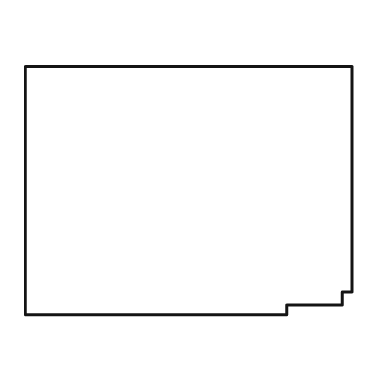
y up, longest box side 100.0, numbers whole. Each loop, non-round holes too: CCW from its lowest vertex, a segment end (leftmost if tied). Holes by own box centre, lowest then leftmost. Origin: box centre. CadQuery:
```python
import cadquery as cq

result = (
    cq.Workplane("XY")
    .moveTo(-50.0, -38.0)
    .lineTo(30.0, -38.0)
    .lineTo(30.0, -35.0)
    .lineTo(47.0, -35.0)
    .lineTo(47.0, -31.0)
    .lineTo(50.0, -31.0)
    .lineTo(50.0, 38.0)
    .lineTo(-50.0, 38.0)
    .close()
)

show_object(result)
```